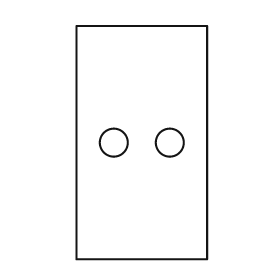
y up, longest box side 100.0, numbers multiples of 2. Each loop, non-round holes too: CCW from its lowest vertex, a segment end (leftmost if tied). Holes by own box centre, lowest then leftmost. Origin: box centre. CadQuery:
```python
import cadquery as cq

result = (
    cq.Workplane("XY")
    .moveTo(-28.0, -50.0)
    .lineTo(28.0, -50.0)
    .lineTo(28.0, 50.0)
    .lineTo(-28.0, 50.0)
    .close()
    .moveTo(-12.0, 0.0)
    .circle(6.0)
    .moveTo(12.0, 0.0)
    .circle(6.0)
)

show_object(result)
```